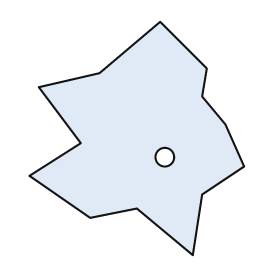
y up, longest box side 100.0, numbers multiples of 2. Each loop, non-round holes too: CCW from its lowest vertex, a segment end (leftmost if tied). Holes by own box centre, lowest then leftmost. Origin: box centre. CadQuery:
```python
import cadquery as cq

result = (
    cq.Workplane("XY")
    .moveTo(24.0, -50.0)
    .lineTo(28.0, -24.0)
    .lineTo(46.0, -12.0)
    .lineTo(38.0, 6.0)
    .lineTo(28.0, 18.0)
    .lineTo(30.0, 30.0)
    .lineTo(10.0, 50.0)
    .lineTo(-16.0, 28.0)
    .lineTo(-42.0, 22.0)
    .lineTo(-24.0, -2.0)
    .lineTo(-46.0, -16.0)
    .lineTo(-20.0, -34.0)
    .lineTo(0.0, -30.0)
    .close()
    .moveTo(12.0, -8.0)
    .circle(4.0)
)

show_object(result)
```